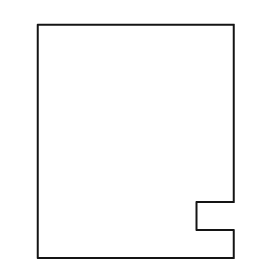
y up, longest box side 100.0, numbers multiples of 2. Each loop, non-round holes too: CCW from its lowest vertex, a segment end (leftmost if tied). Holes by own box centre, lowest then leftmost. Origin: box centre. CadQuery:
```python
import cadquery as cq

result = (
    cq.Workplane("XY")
    .moveTo(-42.0, -50.0)
    .lineTo(42.0, -50.0)
    .lineTo(42.0, -38.0)
    .lineTo(26.0, -38.0)
    .lineTo(26.0, -26.0)
    .lineTo(42.0, -26.0)
    .lineTo(42.0, 50.0)
    .lineTo(-42.0, 50.0)
    .close()
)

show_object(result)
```